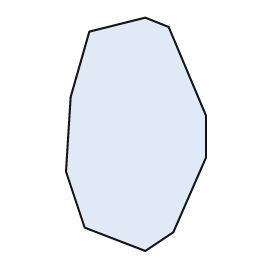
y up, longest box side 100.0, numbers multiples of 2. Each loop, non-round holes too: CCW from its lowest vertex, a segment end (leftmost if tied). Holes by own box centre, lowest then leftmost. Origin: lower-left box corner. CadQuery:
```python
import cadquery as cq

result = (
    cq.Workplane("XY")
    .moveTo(34.0, 0.0)
    .lineTo(46.0, 8.0)
    .lineTo(60.0, 40.0)
    .lineTo(60.0, 58.0)
    .lineTo(44.0, 96.0)
    .lineTo(34.0, 100.0)
    .lineTo(10.0, 94.0)
    .lineTo(2.0, 66.0)
    .lineTo(0.0, 34.0)
    .lineTo(8.0, 10.0)
    .close()
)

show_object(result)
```